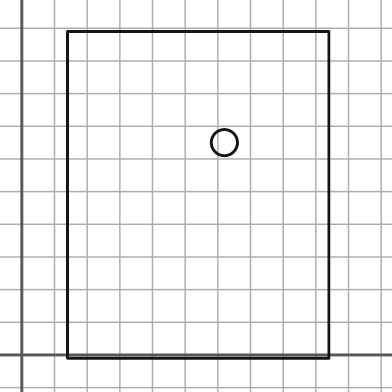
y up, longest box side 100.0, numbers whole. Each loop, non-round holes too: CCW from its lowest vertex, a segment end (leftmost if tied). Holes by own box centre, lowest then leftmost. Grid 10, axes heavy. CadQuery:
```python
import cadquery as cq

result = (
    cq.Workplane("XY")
    .moveTo(14.0, -1.0)
    .lineTo(94.0, -1.0)
    .lineTo(94.0, 99.0)
    .lineTo(14.0, 99.0)
    .close()
    .moveTo(62.0, 65.0)
    .circle(4.0)
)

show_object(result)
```